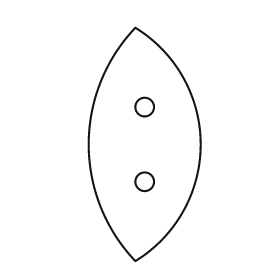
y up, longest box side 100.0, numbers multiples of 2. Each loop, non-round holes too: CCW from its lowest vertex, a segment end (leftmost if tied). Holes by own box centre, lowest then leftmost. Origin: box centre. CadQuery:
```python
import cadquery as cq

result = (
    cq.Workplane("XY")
    .moveTo(-4.0, -50.0)
    .threePointArc((24.0, 0.0), (-4.0, 50.0))
    .threePointArc((-24.0, 0.0), (-4.0, -50.0))
    .close()
    .moveTo(0.0, -16.0)
    .circle(4.0)
    .moveTo(0.0, 16.0)
    .circle(4.0)
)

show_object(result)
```